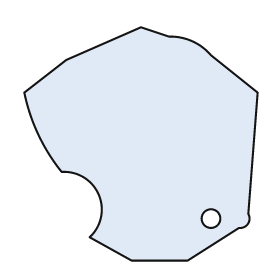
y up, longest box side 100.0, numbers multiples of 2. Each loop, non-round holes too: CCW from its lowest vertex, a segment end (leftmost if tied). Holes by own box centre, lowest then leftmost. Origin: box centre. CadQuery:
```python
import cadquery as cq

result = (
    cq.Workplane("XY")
    .moveTo(-4.0, -50.0)
    .lineTo(20.0, -50.0)
    .lineTo(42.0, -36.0)
    .threePointArc((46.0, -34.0), (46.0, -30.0))
    .lineTo(50.0, 22.0)
    .lineTo(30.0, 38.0)
    .threePointArc((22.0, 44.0), (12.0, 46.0))
    .lineTo(0.0, 50.0)
    .lineTo(-32.0, 36.0)
    .lineTo(-50.0, 22.0)
    .threePointArc((-44.0, 4.0), (-34.0, -12.0))
    .threePointArc((-18.0, -22.0), (-22.0, -40.0))
    .close()
    .moveTo(30.0, -32.0)
    .circle(4.0)
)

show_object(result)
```